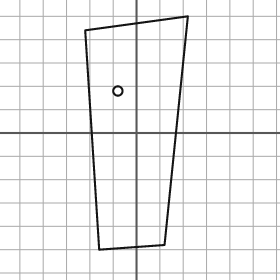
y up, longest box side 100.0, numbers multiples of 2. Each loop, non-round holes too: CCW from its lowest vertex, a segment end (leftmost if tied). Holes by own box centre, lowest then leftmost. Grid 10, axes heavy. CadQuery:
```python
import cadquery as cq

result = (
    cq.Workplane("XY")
    .moveTo(-16.0, -50.0)
    .lineTo(12.0, -48.0)
    .lineTo(22.0, 50.0)
    .lineTo(-22.0, 44.0)
    .close()
    .moveTo(-8.0, 18.0)
    .circle(2.0)
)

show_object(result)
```